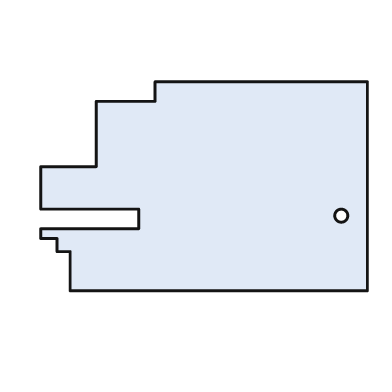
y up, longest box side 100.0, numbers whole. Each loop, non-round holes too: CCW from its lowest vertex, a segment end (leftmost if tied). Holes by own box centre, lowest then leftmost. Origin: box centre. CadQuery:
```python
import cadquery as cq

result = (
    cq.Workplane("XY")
    .moveTo(-41.0, -32.0)
    .lineTo(50.0, -32.0)
    .lineTo(50.0, 32.0)
    .lineTo(-15.0, 32.0)
    .lineTo(-15.0, 26.0)
    .lineTo(-33.0, 26.0)
    .lineTo(-33.0, 6.0)
    .lineTo(-50.0, 6.0)
    .lineTo(-50.0, -7.0)
    .lineTo(-20.0, -7.0)
    .lineTo(-20.0, -13.0)
    .lineTo(-50.0, -13.0)
    .lineTo(-50.0, -16.0)
    .lineTo(-45.0, -16.0)
    .lineTo(-45.0, -20.0)
    .lineTo(-41.0, -20.0)
    .close()
    .moveTo(42.0, -9.0)
    .circle(2.0)
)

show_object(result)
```